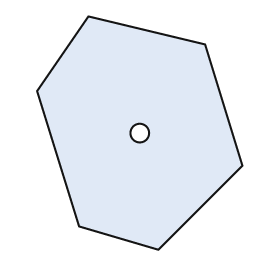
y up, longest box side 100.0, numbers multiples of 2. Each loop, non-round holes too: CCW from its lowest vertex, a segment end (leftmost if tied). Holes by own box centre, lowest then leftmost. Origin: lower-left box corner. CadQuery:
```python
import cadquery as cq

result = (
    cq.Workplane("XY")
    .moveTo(52.0, 0.0)
    .lineTo(88.0, 36.0)
    .lineTo(72.0, 88.0)
    .lineTo(22.0, 100.0)
    .lineTo(0.0, 68.0)
    .lineTo(18.0, 10.0)
    .close()
    .moveTo(44.0, 50.0)
    .circle(4.0)
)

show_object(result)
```